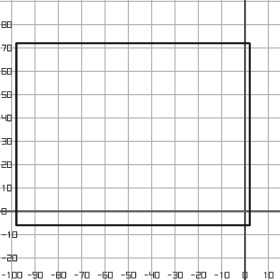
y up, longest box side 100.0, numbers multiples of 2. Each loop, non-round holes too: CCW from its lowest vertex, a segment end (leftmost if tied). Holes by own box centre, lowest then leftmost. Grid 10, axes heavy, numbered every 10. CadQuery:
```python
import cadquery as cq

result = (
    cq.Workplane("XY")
    .moveTo(-98.0, -6.0)
    .lineTo(2.0, -6.0)
    .lineTo(2.0, 72.0)
    .lineTo(-98.0, 72.0)
    .close()
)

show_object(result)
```